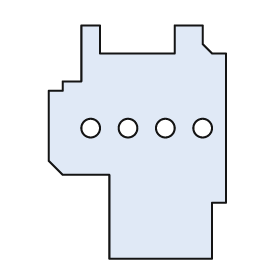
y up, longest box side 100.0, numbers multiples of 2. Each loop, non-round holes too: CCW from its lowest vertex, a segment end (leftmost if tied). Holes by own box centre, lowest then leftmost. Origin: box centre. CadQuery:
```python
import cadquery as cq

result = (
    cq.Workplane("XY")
    .moveTo(-12.0, -50.0)
    .lineTo(32.0, -50.0)
    .lineTo(32.0, -26.0)
    .lineTo(38.0, -26.0)
    .lineTo(38.0, 38.0)
    .lineTo(32.0, 38.0)
    .lineTo(28.0, 42.0)
    .lineTo(28.0, 50.0)
    .lineTo(16.0, 50.0)
    .lineTo(16.0, 38.0)
    .lineTo(-16.0, 38.0)
    .lineTo(-16.0, 50.0)
    .lineTo(-24.0, 50.0)
    .lineTo(-24.0, 26.0)
    .lineTo(-32.0, 26.0)
    .lineTo(-32.0, 22.0)
    .lineTo(-38.0, 22.0)
    .lineTo(-38.0, -8.0)
    .lineTo(-32.0, -14.0)
    .lineTo(-12.0, -14.0)
    .close()
    .moveTo(-20.0, 6.0)
    .circle(4.0)
    .moveTo(-4.0, 6.0)
    .circle(4.0)
    .moveTo(12.0, 6.0)
    .circle(4.0)
    .moveTo(28.0, 6.0)
    .circle(4.0)
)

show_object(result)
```